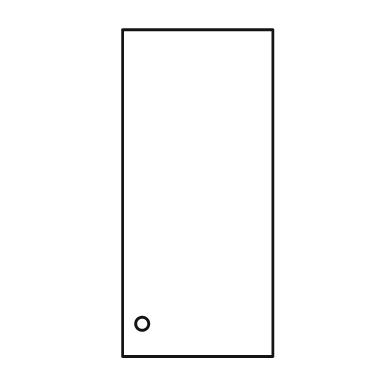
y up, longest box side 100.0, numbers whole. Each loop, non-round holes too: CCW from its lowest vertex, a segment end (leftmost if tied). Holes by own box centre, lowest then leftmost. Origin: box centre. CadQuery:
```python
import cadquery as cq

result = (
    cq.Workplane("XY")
    .moveTo(-23.0, -50.0)
    .lineTo(23.0, -50.0)
    .lineTo(23.0, 50.0)
    .lineTo(-23.0, 50.0)
    .close()
    .moveTo(-17.0, -40.0)
    .circle(2.0)
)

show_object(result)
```